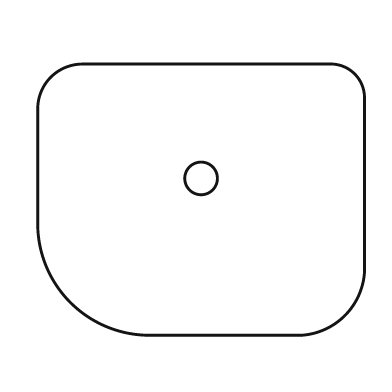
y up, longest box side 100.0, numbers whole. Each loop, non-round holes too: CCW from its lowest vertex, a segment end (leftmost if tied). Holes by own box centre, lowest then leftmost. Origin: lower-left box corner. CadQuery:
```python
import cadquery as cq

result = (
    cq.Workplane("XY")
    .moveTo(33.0, 0.0)
    .lineTo(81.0, 0.0)
    .threePointArc((94.0, 6.0), (100.0, 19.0))
    .lineTo(100.0, 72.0)
    .threePointArc((97.0, 80.0), (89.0, 83.0))
    .lineTo(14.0, 83.0)
    .threePointArc((4.0, 79.0), (0.0, 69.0))
    .lineTo(0.0, 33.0)
    .threePointArc((10.0, 10.0), (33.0, 0.0))
    .close()
    .moveTo(50.0, 48.0)
    .circle(5.0)
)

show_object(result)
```